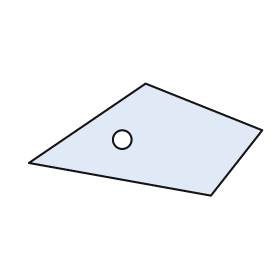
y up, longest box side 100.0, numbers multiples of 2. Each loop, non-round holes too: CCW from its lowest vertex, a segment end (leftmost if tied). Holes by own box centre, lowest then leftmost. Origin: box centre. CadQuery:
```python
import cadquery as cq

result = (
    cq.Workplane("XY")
    .moveTo(28.0, -24.0)
    .lineTo(50.0, 4.0)
    .lineTo(0.0, 24.0)
    .lineTo(-50.0, -10.0)
    .close()
    .moveTo(-10.0, 0.0)
    .circle(4.0)
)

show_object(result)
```